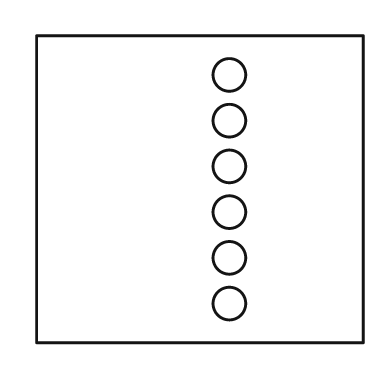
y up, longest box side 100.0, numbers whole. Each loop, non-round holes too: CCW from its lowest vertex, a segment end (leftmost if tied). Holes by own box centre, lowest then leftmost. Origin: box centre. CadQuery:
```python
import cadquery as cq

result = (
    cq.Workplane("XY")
    .moveTo(-50.0, -47.0)
    .lineTo(50.0, -47.0)
    .lineTo(50.0, 47.0)
    .lineTo(-50.0, 47.0)
    .close()
    .moveTo(9.0, -35.0)
    .circle(5.0)
    .moveTo(9.0, -21.0)
    .circle(5.0)
    .moveTo(9.0, -7.0)
    .circle(5.0)
    .moveTo(9.0, 7.0)
    .circle(5.0)
    .moveTo(9.0, 21.0)
    .circle(5.0)
    .moveTo(9.0, 35.0)
    .circle(5.0)
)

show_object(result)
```